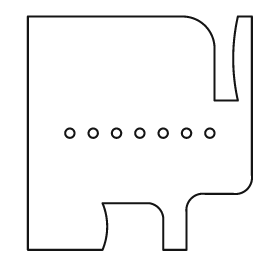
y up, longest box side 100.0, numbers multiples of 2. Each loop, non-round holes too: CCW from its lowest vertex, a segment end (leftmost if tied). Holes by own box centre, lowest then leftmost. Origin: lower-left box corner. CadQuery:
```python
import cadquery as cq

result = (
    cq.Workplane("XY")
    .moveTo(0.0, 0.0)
    .lineTo(32.0, 0.0)
    .threePointArc((34.0, 10.0), (32.0, 20.0))
    .lineTo(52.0, 20.0)
    .threePointArc((56.0, 18.0), (58.0, 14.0))
    .lineTo(58.0, 0.0)
    .lineTo(68.0, 0.0)
    .lineTo(68.0, 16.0)
    .threePointArc((70.0, 22.0), (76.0, 24.0))
    .lineTo(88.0, 24.0)
    .threePointArc((94.0, 26.0), (96.0, 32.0))
    .lineTo(96.0, 100.0)
    .lineTo(90.0, 100.0)
    .threePointArc((88.0, 82.0), (90.0, 64.0))
    .lineTo(80.0, 64.0)
    .lineTo(80.0, 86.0)
    .threePointArc((76.0, 96.0), (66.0, 100.0))
    .lineTo(0.0, 100.0)
    .close()
    .moveTo(18.0, 50.0)
    .circle(2.0)
    .moveTo(28.0, 50.0)
    .circle(2.0)
    .moveTo(38.0, 50.0)
    .circle(2.0)
    .moveTo(48.0, 50.0)
    .circle(2.0)
    .moveTo(58.0, 50.0)
    .circle(2.0)
    .moveTo(68.0, 50.0)
    .circle(2.0)
    .moveTo(78.0, 50.0)
    .circle(2.0)
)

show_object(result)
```